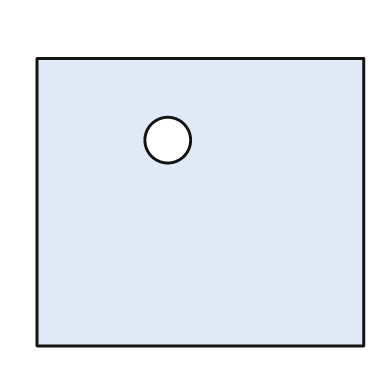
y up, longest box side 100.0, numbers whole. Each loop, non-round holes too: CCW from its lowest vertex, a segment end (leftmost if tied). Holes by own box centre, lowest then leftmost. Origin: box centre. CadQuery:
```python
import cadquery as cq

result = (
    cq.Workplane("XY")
    .moveTo(-50.0, -44.0)
    .lineTo(50.0, -44.0)
    .lineTo(50.0, 44.0)
    .lineTo(-50.0, 44.0)
    .close()
    .moveTo(-10.0, 19.0)
    .circle(7.0)
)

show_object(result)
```